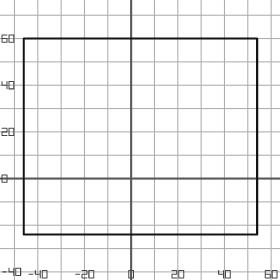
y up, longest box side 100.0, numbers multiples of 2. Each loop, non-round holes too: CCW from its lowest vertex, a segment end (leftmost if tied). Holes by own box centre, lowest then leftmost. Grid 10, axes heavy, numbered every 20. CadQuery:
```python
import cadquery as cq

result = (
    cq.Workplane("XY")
    .moveTo(-46.0, -24.0)
    .lineTo(54.0, -24.0)
    .lineTo(54.0, 60.0)
    .lineTo(-46.0, 60.0)
    .close()
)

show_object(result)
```